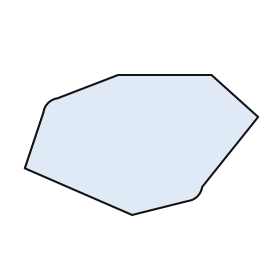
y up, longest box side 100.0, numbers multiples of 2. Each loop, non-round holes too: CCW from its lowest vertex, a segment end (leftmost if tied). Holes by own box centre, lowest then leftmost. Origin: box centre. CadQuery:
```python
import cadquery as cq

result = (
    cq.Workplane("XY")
    .moveTo(-4.0, -30.0)
    .lineTo(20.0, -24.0)
    .threePointArc((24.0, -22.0), (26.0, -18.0))
    .lineTo(50.0, 12.0)
    .lineTo(30.0, 30.0)
    .lineTo(-10.0, 30.0)
    .lineTo(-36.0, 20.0)
    .threePointArc((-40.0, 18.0), (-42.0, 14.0))
    .lineTo(-50.0, -10.0)
    .close()
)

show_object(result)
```